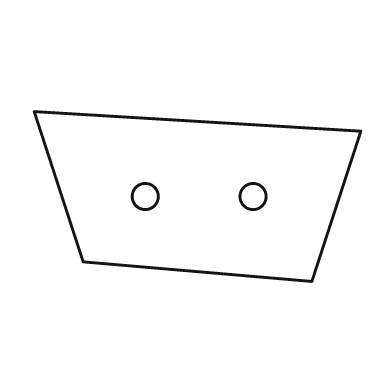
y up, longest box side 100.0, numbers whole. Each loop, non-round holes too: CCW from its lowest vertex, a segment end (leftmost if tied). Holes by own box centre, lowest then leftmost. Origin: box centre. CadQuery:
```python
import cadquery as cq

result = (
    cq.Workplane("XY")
    .moveTo(35.0, -26.0)
    .lineTo(50.0, 20.0)
    .lineTo(-50.0, 26.0)
    .lineTo(-35.0, -20.0)
    .close()
    .moveTo(-16.0, 0.0)
    .circle(4.0)
    .moveTo(17.0, 0.0)
    .circle(4.0)
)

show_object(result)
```